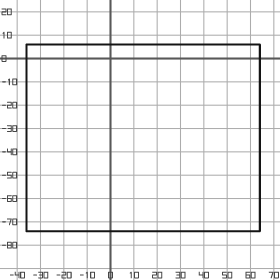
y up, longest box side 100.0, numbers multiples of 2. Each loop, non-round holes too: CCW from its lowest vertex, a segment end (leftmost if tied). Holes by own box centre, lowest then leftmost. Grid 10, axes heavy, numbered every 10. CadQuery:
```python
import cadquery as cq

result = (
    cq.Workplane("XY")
    .moveTo(-36.0, -74.0)
    .lineTo(64.0, -74.0)
    .lineTo(64.0, 6.0)
    .lineTo(-36.0, 6.0)
    .close()
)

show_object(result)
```